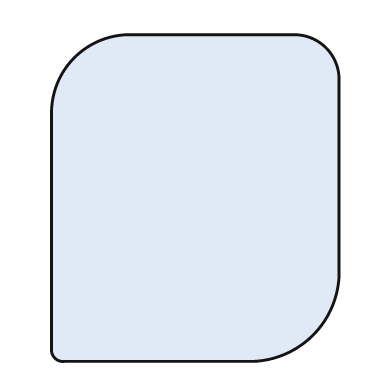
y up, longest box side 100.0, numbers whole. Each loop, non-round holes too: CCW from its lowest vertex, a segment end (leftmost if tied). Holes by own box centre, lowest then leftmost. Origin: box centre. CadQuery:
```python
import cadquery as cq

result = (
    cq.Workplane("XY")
    .moveTo(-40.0, -50.0)
    .lineTo(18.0, -50.0)
    .threePointArc((36.0, -42.0), (44.0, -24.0))
    .lineTo(44.0, 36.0)
    .threePointArc((40.0, 46.0), (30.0, 50.0))
    .lineTo(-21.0, 50.0)
    .threePointArc((-37.0, 43.0), (-44.0, 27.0))
    .lineTo(-44.0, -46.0)
    .threePointArc((-43.0, -49.0), (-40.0, -50.0))
    .close()
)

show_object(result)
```